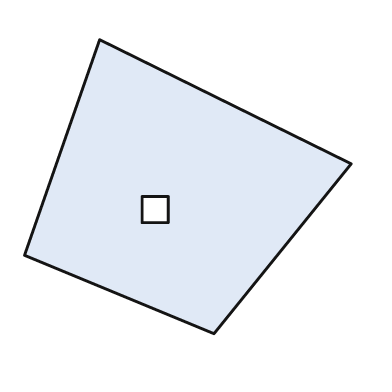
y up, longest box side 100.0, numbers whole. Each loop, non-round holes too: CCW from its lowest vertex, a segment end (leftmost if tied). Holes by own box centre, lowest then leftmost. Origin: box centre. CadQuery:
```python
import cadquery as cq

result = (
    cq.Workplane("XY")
    .moveTo(8.0, -45.0)
    .lineTo(50.0, 7.0)
    .lineTo(-27.0, 45.0)
    .lineTo(-50.0, -21.0)
    .close()
    .moveTo(-14.0, -11.0)
    .lineTo(-6.0, -11.0)
    .lineTo(-6.0, -3.0)
    .lineTo(-14.0, -3.0)
    .close()
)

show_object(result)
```